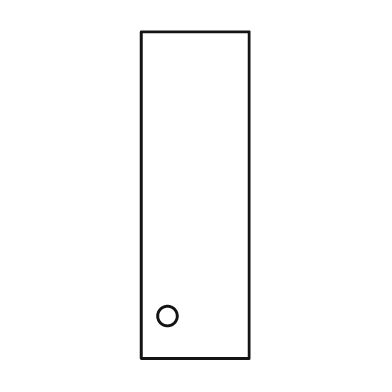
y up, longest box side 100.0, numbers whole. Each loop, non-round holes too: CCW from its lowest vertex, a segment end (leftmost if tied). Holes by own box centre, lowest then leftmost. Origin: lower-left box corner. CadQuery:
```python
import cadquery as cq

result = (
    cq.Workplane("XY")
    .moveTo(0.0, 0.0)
    .lineTo(33.0, 0.0)
    .lineTo(33.0, 100.0)
    .lineTo(0.0, 100.0)
    .close()
    .moveTo(8.0, 13.0)
    .circle(3.0)
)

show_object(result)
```